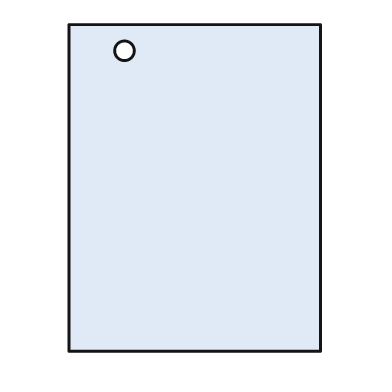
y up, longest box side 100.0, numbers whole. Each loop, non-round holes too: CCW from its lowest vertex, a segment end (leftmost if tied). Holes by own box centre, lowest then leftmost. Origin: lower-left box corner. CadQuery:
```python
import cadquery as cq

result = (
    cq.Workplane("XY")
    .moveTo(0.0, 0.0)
    .lineTo(77.0, 0.0)
    .lineTo(77.0, 100.0)
    .lineTo(0.0, 100.0)
    .close()
    .moveTo(17.0, 92.0)
    .circle(3.0)
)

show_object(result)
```